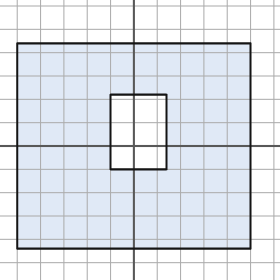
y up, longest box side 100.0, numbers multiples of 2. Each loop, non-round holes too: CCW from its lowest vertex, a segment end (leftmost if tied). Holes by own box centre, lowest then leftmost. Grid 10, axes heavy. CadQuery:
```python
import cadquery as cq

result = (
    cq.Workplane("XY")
    .moveTo(-50.0, -44.0)
    .lineTo(50.0, -44.0)
    .lineTo(50.0, 44.0)
    .lineTo(-50.0, 44.0)
    .close()
    .moveTo(-10.0, -10.0)
    .lineTo(14.0, -10.0)
    .lineTo(14.0, 22.0)
    .lineTo(-10.0, 22.0)
    .close()
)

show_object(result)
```